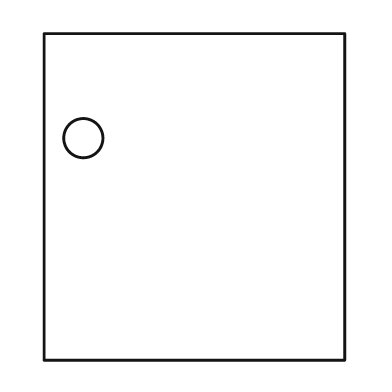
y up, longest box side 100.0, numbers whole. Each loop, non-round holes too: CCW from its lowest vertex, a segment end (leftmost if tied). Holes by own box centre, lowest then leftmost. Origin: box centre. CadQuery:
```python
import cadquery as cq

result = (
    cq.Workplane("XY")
    .moveTo(-46.0, -50.0)
    .lineTo(46.0, -50.0)
    .lineTo(46.0, 50.0)
    .lineTo(-46.0, 50.0)
    .close()
    .moveTo(-34.0, 18.0)
    .circle(6.0)
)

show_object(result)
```